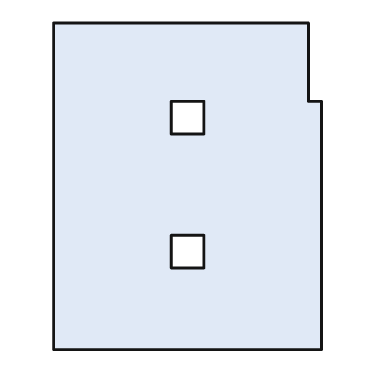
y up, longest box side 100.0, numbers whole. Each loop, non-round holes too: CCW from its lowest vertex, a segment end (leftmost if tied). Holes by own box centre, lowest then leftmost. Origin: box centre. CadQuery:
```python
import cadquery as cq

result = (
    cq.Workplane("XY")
    .moveTo(-41.0, -50.0)
    .lineTo(41.0, -50.0)
    .lineTo(41.0, 26.0)
    .lineTo(37.0, 26.0)
    .lineTo(37.0, 50.0)
    .lineTo(-41.0, 50.0)
    .close()
    .moveTo(-5.0, -25.0)
    .lineTo(5.0, -25.0)
    .lineTo(5.0, -15.0)
    .lineTo(-5.0, -15.0)
    .close()
    .moveTo(-5.0, 16.0)
    .lineTo(5.0, 16.0)
    .lineTo(5.0, 26.0)
    .lineTo(-5.0, 26.0)
    .close()
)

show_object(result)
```